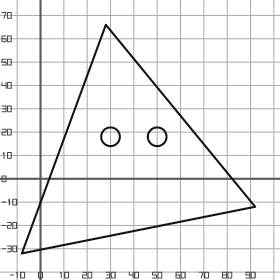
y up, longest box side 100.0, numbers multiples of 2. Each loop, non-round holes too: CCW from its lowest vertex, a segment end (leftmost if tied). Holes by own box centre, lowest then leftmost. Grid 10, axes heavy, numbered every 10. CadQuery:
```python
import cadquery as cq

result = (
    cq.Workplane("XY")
    .moveTo(-8.0, -32.0)
    .lineTo(92.0, -12.0)
    .lineTo(28.0, 66.0)
    .close()
    .moveTo(30.0, 18.0)
    .circle(4.0)
    .moveTo(50.0, 18.0)
    .circle(4.0)
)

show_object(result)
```